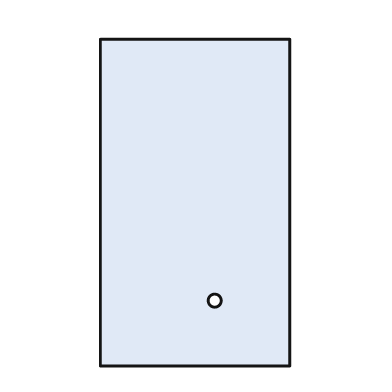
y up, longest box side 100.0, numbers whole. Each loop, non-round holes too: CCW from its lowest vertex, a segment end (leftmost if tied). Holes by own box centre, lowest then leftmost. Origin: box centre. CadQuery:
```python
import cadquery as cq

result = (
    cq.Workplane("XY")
    .moveTo(-29.0, -50.0)
    .lineTo(29.0, -50.0)
    .lineTo(29.0, 50.0)
    .lineTo(-29.0, 50.0)
    .close()
    .moveTo(6.0, -30.0)
    .circle(2.0)
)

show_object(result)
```